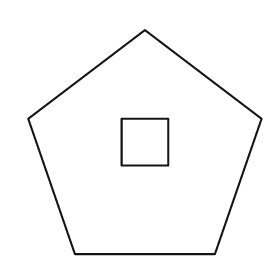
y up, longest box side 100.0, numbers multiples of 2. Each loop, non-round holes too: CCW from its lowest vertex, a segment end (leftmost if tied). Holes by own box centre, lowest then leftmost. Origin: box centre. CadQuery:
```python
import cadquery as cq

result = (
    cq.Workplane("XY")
    .moveTo(-30.0, -48.0)
    .lineTo(30.0, -48.0)
    .lineTo(50.0, 10.0)
    .lineTo(0.0, 48.0)
    .lineTo(-50.0, 10.0)
    .close()
    .moveTo(-10.0, -10.0)
    .lineTo(10.0, -10.0)
    .lineTo(10.0, 10.0)
    .lineTo(-10.0, 10.0)
    .close()
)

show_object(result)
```